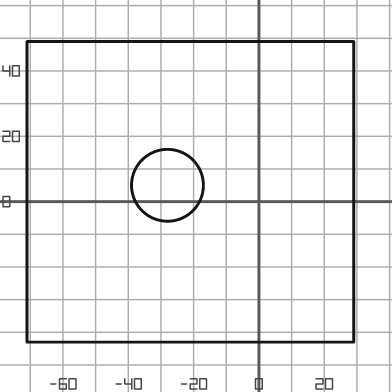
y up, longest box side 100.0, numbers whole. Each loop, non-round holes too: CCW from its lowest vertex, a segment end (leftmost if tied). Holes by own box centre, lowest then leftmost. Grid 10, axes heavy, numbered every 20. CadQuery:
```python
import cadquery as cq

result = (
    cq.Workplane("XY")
    .moveTo(-71.0, -43.0)
    .lineTo(29.0, -43.0)
    .lineTo(29.0, 49.0)
    .lineTo(-71.0, 49.0)
    .close()
    .moveTo(-28.0, 5.0)
    .circle(11.0)
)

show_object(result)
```